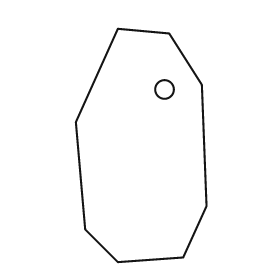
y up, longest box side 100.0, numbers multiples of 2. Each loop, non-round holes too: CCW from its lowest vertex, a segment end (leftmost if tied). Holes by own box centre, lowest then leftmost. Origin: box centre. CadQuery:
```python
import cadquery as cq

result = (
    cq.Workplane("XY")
    .moveTo(-10.0, -50.0)
    .lineTo(18.0, -48.0)
    .lineTo(28.0, -26.0)
    .lineTo(26.0, 26.0)
    .lineTo(12.0, 48.0)
    .lineTo(-10.0, 50.0)
    .lineTo(-28.0, 10.0)
    .lineTo(-24.0, -36.0)
    .close()
    .moveTo(10.0, 24.0)
    .circle(4.0)
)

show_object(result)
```